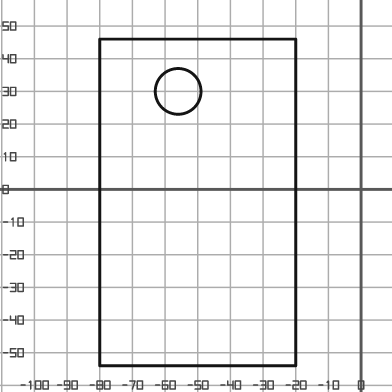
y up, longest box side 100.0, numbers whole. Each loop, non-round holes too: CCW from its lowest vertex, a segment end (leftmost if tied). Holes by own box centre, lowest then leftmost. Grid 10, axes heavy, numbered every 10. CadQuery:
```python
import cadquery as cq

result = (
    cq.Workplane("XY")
    .moveTo(-80.0, -54.0)
    .lineTo(-20.0, -54.0)
    .lineTo(-20.0, 46.0)
    .lineTo(-80.0, 46.0)
    .close()
    .moveTo(-56.0, 30.0)
    .circle(7.0)
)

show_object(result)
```